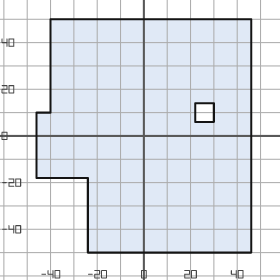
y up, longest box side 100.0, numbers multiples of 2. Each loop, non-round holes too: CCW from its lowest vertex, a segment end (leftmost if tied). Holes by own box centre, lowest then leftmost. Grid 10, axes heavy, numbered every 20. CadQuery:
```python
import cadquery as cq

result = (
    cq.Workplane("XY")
    .moveTo(-24.0, -50.0)
    .lineTo(46.0, -50.0)
    .lineTo(46.0, 50.0)
    .lineTo(-40.0, 50.0)
    .lineTo(-40.0, 10.0)
    .lineTo(-46.0, 10.0)
    .lineTo(-46.0, -18.0)
    .lineTo(-24.0, -18.0)
    .close()
    .moveTo(22.0, 6.0)
    .lineTo(30.0, 6.0)
    .lineTo(30.0, 14.0)
    .lineTo(22.0, 14.0)
    .close()
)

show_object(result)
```